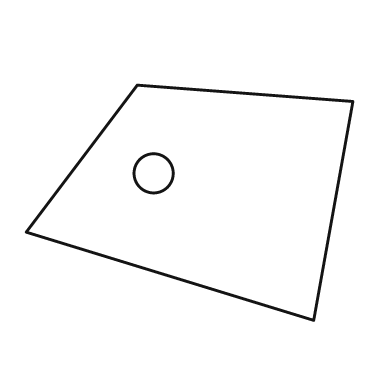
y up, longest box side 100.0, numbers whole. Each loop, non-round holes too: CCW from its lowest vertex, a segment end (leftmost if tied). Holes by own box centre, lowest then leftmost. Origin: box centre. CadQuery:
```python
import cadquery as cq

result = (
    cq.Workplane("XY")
    .moveTo(38.0, -36.0)
    .lineTo(50.0, 31.0)
    .lineTo(-16.0, 36.0)
    .lineTo(-50.0, -9.0)
    .close()
    .moveTo(-11.0, 9.0)
    .circle(6.0)
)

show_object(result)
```